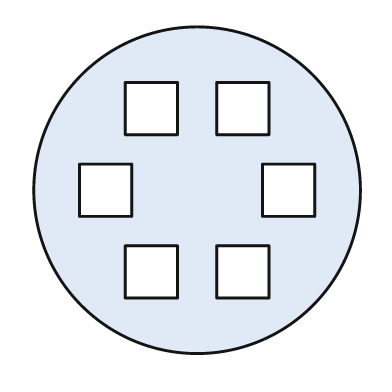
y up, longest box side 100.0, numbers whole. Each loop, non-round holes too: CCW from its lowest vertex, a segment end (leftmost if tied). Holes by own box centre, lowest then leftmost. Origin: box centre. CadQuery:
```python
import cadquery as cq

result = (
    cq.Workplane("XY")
    .moveTo(0.0, 0.0)
    .circle(50.0)
    .moveTo(-22.0, -33.0)
    .lineTo(-6.0, -33.0)
    .lineTo(-6.0, -17.0)
    .lineTo(-22.0, -17.0)
    .close()
    .moveTo(6.0, -33.0)
    .lineTo(22.0, -33.0)
    .lineTo(22.0, -17.0)
    .lineTo(6.0, -17.0)
    .close()
    .moveTo(-36.0, -8.0)
    .lineTo(-20.0, -8.0)
    .lineTo(-20.0, 8.0)
    .lineTo(-36.0, 8.0)
    .close()
    .moveTo(20.0, -8.0)
    .lineTo(36.0, -8.0)
    .lineTo(36.0, 8.0)
    .lineTo(20.0, 8.0)
    .close()
    .moveTo(-22.0, 17.0)
    .lineTo(-6.0, 17.0)
    .lineTo(-6.0, 33.0)
    .lineTo(-22.0, 33.0)
    .close()
    .moveTo(6.0, 17.0)
    .lineTo(22.0, 17.0)
    .lineTo(22.0, 33.0)
    .lineTo(6.0, 33.0)
    .close()
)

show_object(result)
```